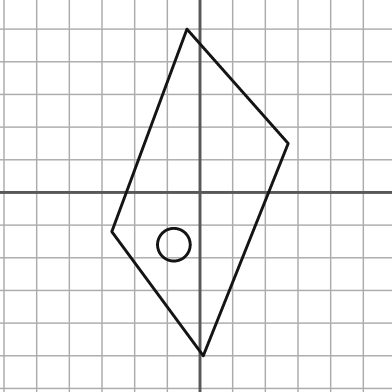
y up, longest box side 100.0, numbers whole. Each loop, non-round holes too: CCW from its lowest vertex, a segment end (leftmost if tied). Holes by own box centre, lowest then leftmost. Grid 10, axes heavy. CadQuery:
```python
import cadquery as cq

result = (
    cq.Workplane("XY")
    .moveTo(1.0, -50.0)
    .lineTo(27.0, 15.0)
    .lineTo(-4.0, 50.0)
    .lineTo(-27.0, -12.0)
    .close()
    .moveTo(-8.0, -16.0)
    .circle(5.0)
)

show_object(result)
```